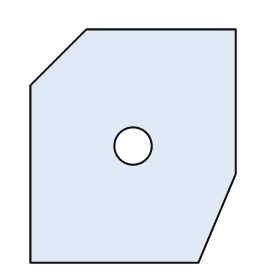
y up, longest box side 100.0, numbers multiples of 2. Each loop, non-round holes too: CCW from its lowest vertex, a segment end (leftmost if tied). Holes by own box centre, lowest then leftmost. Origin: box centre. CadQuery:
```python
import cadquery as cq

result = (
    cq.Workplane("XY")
    .moveTo(-44.0, -50.0)
    .lineTo(28.0, -50.0)
    .lineTo(44.0, -12.0)
    .lineTo(44.0, 50.0)
    .lineTo(-20.0, 50.0)
    .lineTo(-44.0, 26.0)
    .close()
    .moveTo(0.0, 0.0)
    .circle(8.0)
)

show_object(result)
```